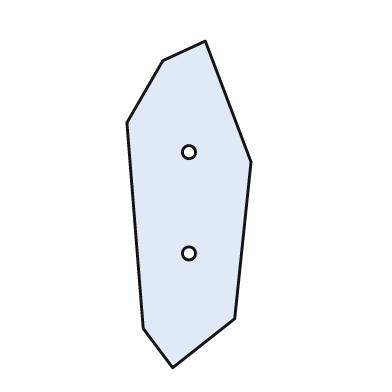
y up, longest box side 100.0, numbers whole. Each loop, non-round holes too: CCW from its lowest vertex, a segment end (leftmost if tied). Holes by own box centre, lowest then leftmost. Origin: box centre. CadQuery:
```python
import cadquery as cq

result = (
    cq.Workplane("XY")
    .moveTo(-5.0, -50.0)
    .lineTo(14.0, -35.0)
    .lineTo(19.0, 13.0)
    .lineTo(5.0, 50.0)
    .lineTo(-8.0, 44.0)
    .lineTo(-19.0, 25.0)
    .lineTo(-14.0, -38.0)
    .close()
    .moveTo(0.0, -15.0)
    .circle(2.0)
    .moveTo(0.0, 16.0)
    .circle(2.0)
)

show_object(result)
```